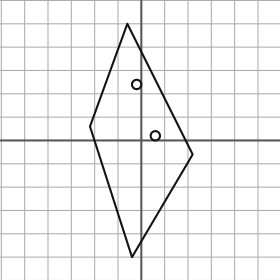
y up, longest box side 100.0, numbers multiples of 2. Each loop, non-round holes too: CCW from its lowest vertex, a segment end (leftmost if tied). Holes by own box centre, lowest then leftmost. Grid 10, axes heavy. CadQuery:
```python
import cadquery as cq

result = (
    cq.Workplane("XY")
    .moveTo(-4.0, -50.0)
    .lineTo(22.0, -6.0)
    .lineTo(-6.0, 50.0)
    .lineTo(-22.0, 6.0)
    .close()
    .moveTo(6.0, 2.0)
    .circle(2.0)
    .moveTo(-2.0, 24.0)
    .circle(2.0)
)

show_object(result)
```